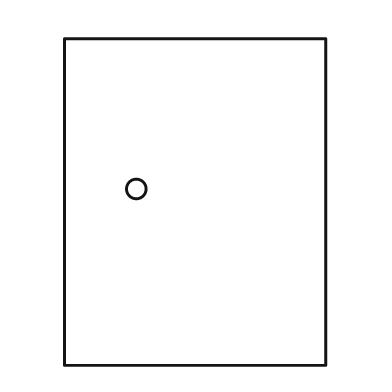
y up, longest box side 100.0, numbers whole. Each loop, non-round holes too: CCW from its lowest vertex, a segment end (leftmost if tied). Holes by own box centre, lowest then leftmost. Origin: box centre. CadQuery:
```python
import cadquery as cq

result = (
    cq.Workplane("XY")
    .moveTo(-40.0, -50.0)
    .lineTo(40.0, -50.0)
    .lineTo(40.0, 50.0)
    .lineTo(-40.0, 50.0)
    .close()
    .moveTo(-18.0, 4.0)
    .circle(3.0)
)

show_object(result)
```